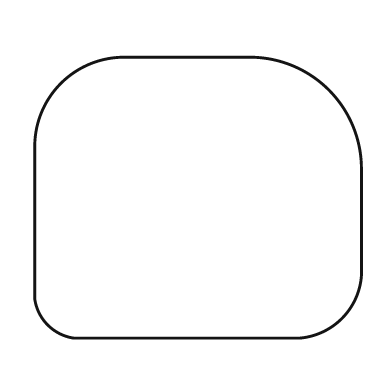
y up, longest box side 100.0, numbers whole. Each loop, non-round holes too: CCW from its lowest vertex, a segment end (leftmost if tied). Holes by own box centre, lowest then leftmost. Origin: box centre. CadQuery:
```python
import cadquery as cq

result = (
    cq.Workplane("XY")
    .moveTo(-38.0, -43.0)
    .lineTo(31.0, -43.0)
    .threePointArc((44.0, -37.0), (50.0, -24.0))
    .lineTo(50.0, 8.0)
    .threePointArc((40.0, 33.0), (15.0, 43.0))
    .lineTo(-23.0, 43.0)
    .threePointArc((-42.0, 35.0), (-50.0, 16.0))
    .lineTo(-50.0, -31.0)
    .threePointArc((-46.0, -39.0), (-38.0, -43.0))
    .close()
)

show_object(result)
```